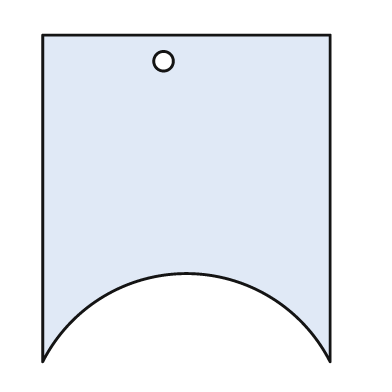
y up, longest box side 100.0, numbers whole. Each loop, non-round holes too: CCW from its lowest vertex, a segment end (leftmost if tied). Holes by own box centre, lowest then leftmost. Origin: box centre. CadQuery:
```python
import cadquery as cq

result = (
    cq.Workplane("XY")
    .moveTo(-44.0, -50.0)
    .threePointArc((0.0, -23.0), (44.0, -50.0))
    .lineTo(44.0, 50.0)
    .lineTo(-44.0, 50.0)
    .close()
    .moveTo(-7.0, 42.0)
    .circle(3.0)
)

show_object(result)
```